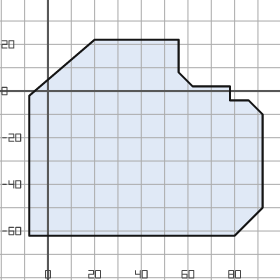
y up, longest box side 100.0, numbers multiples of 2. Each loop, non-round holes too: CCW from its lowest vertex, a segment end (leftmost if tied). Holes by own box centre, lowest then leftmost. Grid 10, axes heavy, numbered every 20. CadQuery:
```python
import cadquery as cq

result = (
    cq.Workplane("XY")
    .moveTo(-8.0, -62.0)
    .lineTo(80.0, -62.0)
    .lineTo(92.0, -50.0)
    .lineTo(92.0, -10.0)
    .lineTo(86.0, -4.0)
    .lineTo(78.0, -4.0)
    .lineTo(78.0, 2.0)
    .lineTo(62.0, 2.0)
    .lineTo(56.0, 8.0)
    .lineTo(56.0, 22.0)
    .lineTo(20.0, 22.0)
    .lineTo(-8.0, -2.0)
    .close()
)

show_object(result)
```